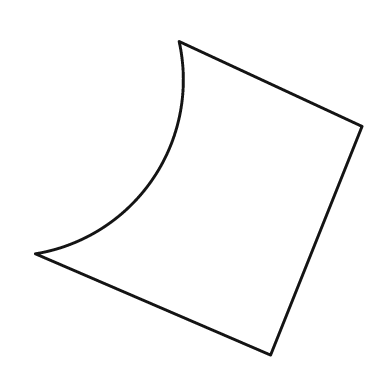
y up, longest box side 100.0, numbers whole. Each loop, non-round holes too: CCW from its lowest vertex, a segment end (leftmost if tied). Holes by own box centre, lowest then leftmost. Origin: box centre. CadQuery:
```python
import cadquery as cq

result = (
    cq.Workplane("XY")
    .moveTo(22.0, -48.0)
    .lineTo(50.0, 22.0)
    .lineTo(-6.0, 48.0)
    .threePointArc((-14.0, 6.0), (-50.0, -17.0))
    .close()
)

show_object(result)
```